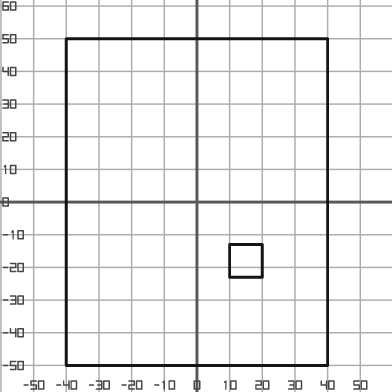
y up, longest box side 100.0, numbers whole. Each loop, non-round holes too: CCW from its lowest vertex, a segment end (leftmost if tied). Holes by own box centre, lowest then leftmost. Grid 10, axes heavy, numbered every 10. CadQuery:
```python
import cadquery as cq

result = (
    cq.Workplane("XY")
    .moveTo(-40.0, -50.0)
    .lineTo(40.0, -50.0)
    .lineTo(40.0, 50.0)
    .lineTo(-40.0, 50.0)
    .close()
    .moveTo(10.0, -23.0)
    .lineTo(20.0, -23.0)
    .lineTo(20.0, -13.0)
    .lineTo(10.0, -13.0)
    .close()
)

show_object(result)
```